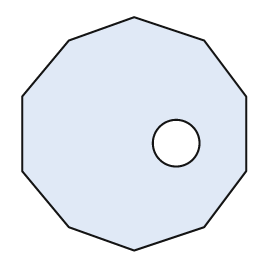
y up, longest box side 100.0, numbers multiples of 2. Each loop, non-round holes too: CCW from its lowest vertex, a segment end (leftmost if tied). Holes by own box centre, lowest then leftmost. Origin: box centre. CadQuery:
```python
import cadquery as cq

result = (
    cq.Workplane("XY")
    .moveTo(0.0, -50.0)
    .lineTo(30.0, -40.0)
    .lineTo(48.0, -16.0)
    .lineTo(48.0, 16.0)
    .lineTo(30.0, 40.0)
    .lineTo(0.0, 50.0)
    .lineTo(-28.0, 40.0)
    .lineTo(-48.0, 16.0)
    .lineTo(-48.0, -16.0)
    .lineTo(-28.0, -40.0)
    .close()
    .moveTo(18.0, -4.0)
    .circle(10.0)
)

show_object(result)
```